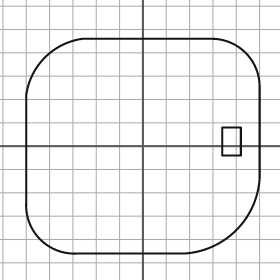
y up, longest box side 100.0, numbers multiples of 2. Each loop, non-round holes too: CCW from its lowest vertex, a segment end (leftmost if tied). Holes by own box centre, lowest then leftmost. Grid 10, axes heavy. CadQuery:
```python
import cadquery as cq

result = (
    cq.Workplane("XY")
    .moveTo(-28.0, -46.0)
    .lineTo(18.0, -46.0)
    .threePointArc((40.0, -36.0), (50.0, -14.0))
    .lineTo(50.0, 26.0)
    .threePointArc((44.0, 40.0), (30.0, 46.0))
    .lineTo(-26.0, 46.0)
    .threePointArc((-42.0, 38.0), (-50.0, 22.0))
    .lineTo(-50.0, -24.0)
    .threePointArc((-44.0, -40.0), (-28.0, -46.0))
    .close()
    .moveTo(34.0, -4.0)
    .lineTo(42.0, -4.0)
    .lineTo(42.0, 8.0)
    .lineTo(34.0, 8.0)
    .close()
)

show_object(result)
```